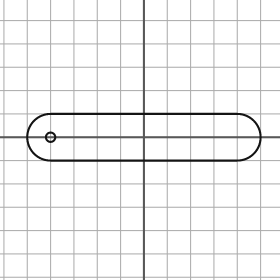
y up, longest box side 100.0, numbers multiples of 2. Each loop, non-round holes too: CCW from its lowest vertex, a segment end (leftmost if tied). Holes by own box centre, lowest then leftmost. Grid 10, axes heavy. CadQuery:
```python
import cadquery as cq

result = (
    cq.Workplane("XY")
    .moveTo(-40.0, -10.0)
    .lineTo(40.0, -10.0)
    .threePointArc((50.0, 0.0), (40.0, 10.0))
    .lineTo(-40.0, 10.0)
    .threePointArc((-50.0, 0.0), (-40.0, -10.0))
    .close()
    .moveTo(-40.0, 0.0)
    .circle(2.0)
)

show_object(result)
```